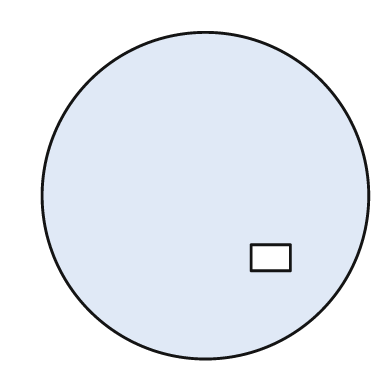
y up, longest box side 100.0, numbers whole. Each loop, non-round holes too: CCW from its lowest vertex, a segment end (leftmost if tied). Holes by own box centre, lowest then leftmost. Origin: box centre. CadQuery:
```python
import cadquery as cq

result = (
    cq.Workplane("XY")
    .moveTo(0.0, 0.0)
    .circle(50.0)
    .moveTo(14.0, -23.0)
    .lineTo(26.0, -23.0)
    .lineTo(26.0, -15.0)
    .lineTo(14.0, -15.0)
    .close()
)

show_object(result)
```